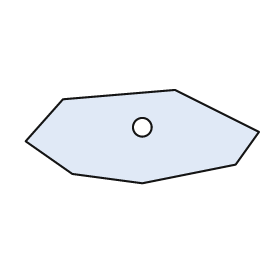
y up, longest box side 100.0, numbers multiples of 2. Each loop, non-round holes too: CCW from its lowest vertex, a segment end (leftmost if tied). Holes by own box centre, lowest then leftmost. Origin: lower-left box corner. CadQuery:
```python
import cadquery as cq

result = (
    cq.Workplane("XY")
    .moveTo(50.0, 0.0)
    .lineTo(90.0, 8.0)
    .lineTo(100.0, 22.0)
    .lineTo(64.0, 40.0)
    .lineTo(16.0, 36.0)
    .lineTo(0.0, 18.0)
    .lineTo(20.0, 4.0)
    .close()
    .moveTo(50.0, 24.0)
    .circle(4.0)
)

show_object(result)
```